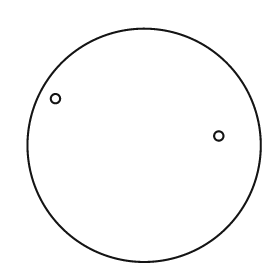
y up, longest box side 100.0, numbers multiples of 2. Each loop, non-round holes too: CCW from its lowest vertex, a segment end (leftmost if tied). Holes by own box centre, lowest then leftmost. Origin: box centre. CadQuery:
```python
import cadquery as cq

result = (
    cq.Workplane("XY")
    .moveTo(0.0, 0.0)
    .circle(50.0)
    .moveTo(32.0, 4.0)
    .circle(2.0)
    .moveTo(-38.0, 20.0)
    .circle(2.0)
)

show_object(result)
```